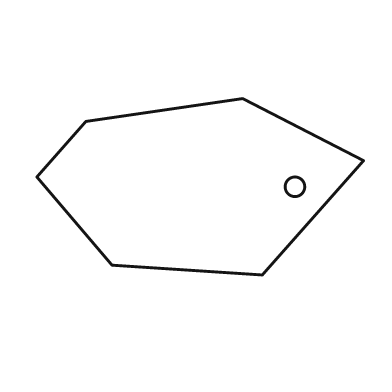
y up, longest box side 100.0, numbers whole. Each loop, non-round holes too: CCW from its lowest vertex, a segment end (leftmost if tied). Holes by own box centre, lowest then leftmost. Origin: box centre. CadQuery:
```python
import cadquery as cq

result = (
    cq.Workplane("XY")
    .moveTo(19.0, -27.0)
    .lineTo(50.0, 8.0)
    .lineTo(13.0, 27.0)
    .lineTo(-35.0, 20.0)
    .lineTo(-50.0, 3.0)
    .lineTo(-27.0, -24.0)
    .close()
    .moveTo(29.0, 0.0)
    .circle(3.0)
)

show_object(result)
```